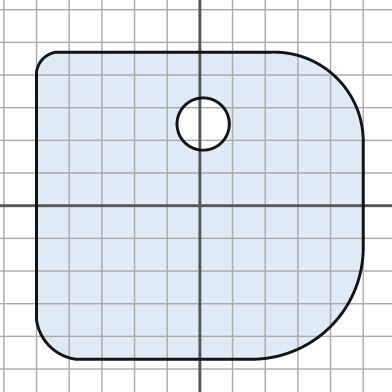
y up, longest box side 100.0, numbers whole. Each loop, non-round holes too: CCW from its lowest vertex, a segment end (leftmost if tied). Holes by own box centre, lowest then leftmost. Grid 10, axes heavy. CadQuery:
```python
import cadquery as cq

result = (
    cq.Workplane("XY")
    .moveTo(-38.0, -47.0)
    .lineTo(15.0, -47.0)
    .threePointArc((40.0, -37.0), (50.0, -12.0))
    .lineTo(50.0, 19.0)
    .threePointArc((42.0, 39.0), (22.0, 47.0))
    .lineTo(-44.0, 47.0)
    .threePointArc((-48.0, 45.0), (-50.0, 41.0))
    .lineTo(-50.0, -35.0)
    .threePointArc((-46.0, -43.0), (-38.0, -47.0))
    .close()
    .moveTo(1.0, 25.0)
    .circle(8.0)
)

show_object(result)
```